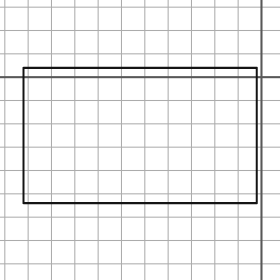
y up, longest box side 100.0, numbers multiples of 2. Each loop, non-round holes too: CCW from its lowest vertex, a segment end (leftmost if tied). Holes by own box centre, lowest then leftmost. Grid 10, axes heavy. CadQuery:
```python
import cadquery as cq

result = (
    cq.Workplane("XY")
    .moveTo(-102.0, -54.0)
    .lineTo(-2.0, -54.0)
    .lineTo(-2.0, 4.0)
    .lineTo(-102.0, 4.0)
    .close()
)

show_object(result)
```